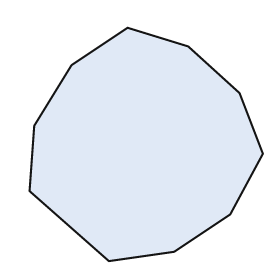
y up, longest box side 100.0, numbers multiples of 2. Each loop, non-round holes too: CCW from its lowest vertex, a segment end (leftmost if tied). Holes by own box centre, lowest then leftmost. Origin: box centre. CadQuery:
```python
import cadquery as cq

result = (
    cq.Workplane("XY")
    .moveTo(-16.0, -50.0)
    .lineTo(12.0, -46.0)
    .lineTo(36.0, -30.0)
    .lineTo(50.0, -4.0)
    .lineTo(40.0, 22.0)
    .lineTo(18.0, 42.0)
    .lineTo(-8.0, 50.0)
    .lineTo(-32.0, 34.0)
    .lineTo(-48.0, 8.0)
    .lineTo(-50.0, -20.0)
    .close()
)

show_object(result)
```